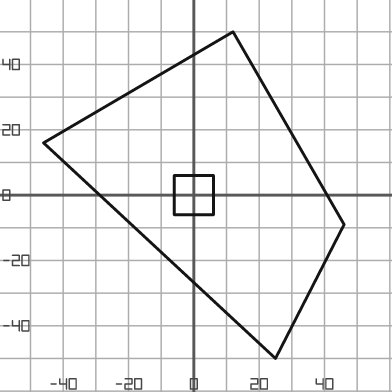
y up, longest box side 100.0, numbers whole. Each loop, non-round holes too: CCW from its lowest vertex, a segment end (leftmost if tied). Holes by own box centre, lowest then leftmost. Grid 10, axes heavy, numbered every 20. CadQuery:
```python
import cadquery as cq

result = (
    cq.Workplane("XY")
    .moveTo(25.0, -50.0)
    .lineTo(46.0, -9.0)
    .lineTo(12.0, 50.0)
    .lineTo(-46.0, 16.0)
    .close()
    .moveTo(-6.0, -6.0)
    .lineTo(6.0, -6.0)
    .lineTo(6.0, 6.0)
    .lineTo(-6.0, 6.0)
    .close()
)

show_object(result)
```